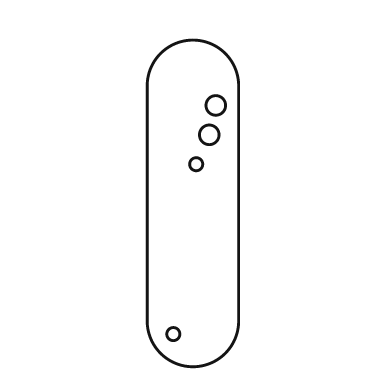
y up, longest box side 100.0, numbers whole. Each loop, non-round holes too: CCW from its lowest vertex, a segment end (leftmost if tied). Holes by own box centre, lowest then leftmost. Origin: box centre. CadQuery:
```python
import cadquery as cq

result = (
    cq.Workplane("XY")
    .moveTo(-14.0, -36.0)
    .threePointArc((0.0, -50.0), (14.0, -36.0))
    .lineTo(14.0, 36.0)
    .threePointArc((0.0, 50.0), (-14.0, 36.0))
    .close()
    .moveTo(-6.0, -40.0)
    .circle(2.0)
    .moveTo(1.0, 12.0)
    .circle(2.0)
    .moveTo(5.0, 21.0)
    .circle(3.0)
    .moveTo(7.0, 30.0)
    .circle(3.0)
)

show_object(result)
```